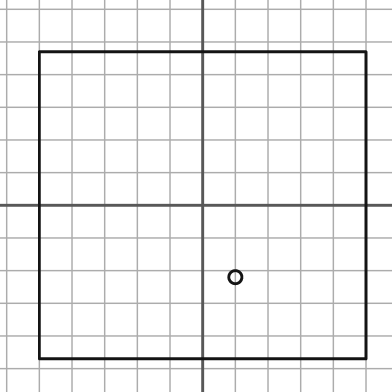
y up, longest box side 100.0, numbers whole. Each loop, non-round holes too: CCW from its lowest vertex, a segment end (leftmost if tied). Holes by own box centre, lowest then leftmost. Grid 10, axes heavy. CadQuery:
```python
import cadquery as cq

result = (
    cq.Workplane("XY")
    .moveTo(-50.0, -47.0)
    .lineTo(50.0, -47.0)
    .lineTo(50.0, 47.0)
    .lineTo(-50.0, 47.0)
    .close()
    .moveTo(10.0, -22.0)
    .circle(2.0)
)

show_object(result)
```